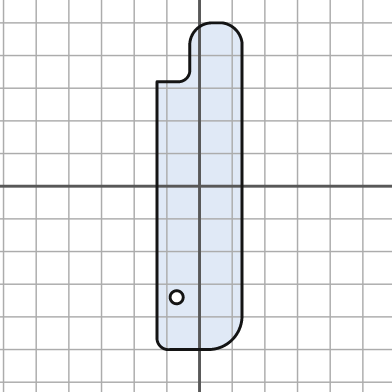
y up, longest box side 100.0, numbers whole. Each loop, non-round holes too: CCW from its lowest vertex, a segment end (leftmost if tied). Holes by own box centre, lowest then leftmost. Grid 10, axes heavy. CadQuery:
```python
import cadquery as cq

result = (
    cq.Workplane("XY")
    .moveTo(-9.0, -50.0)
    .lineTo(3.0, -50.0)
    .threePointArc((10.0, -47.0), (13.0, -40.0))
    .lineTo(13.0, 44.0)
    .threePointArc((11.0, 48.0), (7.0, 50.0))
    .lineTo(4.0, 50.0)
    .threePointArc((-1.0, 48.0), (-3.0, 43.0))
    .lineTo(-3.0, 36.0)
    .threePointArc((-4.0, 33.0), (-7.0, 32.0))
    .lineTo(-13.0, 32.0)
    .lineTo(-13.0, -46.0)
    .threePointArc((-12.0, -49.0), (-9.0, -50.0))
    .close()
    .moveTo(-7.0, -34.0)
    .circle(2.0)
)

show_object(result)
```